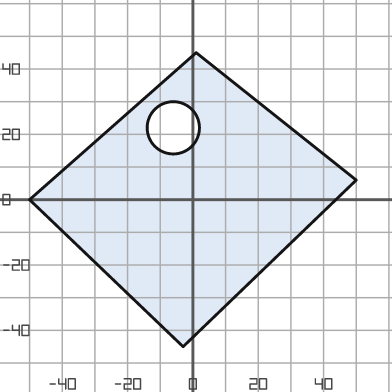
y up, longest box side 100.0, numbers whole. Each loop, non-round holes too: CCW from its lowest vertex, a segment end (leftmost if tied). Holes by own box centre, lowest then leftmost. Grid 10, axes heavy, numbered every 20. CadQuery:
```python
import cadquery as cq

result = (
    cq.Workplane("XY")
    .moveTo(-3.0, -45.0)
    .lineTo(50.0, 6.0)
    .lineTo(1.0, 45.0)
    .lineTo(-50.0, 0.0)
    .close()
    .moveTo(-6.0, 22.0)
    .circle(8.0)
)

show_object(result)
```